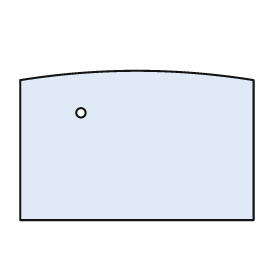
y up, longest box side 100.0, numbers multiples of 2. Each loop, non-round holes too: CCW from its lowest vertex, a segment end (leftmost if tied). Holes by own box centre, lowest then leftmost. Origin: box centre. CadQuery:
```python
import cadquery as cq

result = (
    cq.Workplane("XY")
    .moveTo(-50.0, -32.0)
    .lineTo(50.0, -32.0)
    .lineTo(50.0, 28.0)
    .threePointArc((0.0, 32.0), (-50.0, 28.0))
    .close()
    .moveTo(-24.0, 14.0)
    .circle(2.0)
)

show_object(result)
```